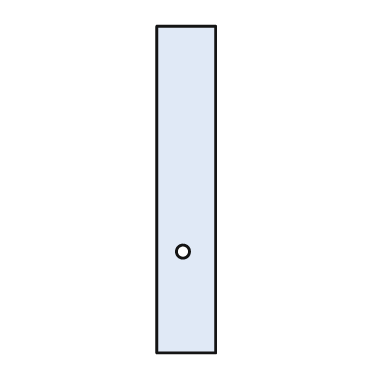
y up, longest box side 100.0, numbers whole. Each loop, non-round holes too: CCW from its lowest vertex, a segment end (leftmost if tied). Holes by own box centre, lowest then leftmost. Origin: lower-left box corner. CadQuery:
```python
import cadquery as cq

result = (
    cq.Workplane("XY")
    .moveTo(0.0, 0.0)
    .lineTo(18.0, 0.0)
    .lineTo(18.0, 100.0)
    .lineTo(0.0, 100.0)
    .close()
    .moveTo(8.0, 31.0)
    .circle(2.0)
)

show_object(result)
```